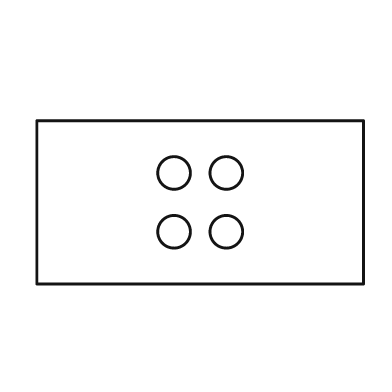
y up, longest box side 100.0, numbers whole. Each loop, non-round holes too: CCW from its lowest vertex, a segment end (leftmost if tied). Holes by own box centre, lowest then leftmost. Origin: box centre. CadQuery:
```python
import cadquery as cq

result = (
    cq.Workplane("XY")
    .moveTo(-50.0, -25.0)
    .lineTo(50.0, -25.0)
    .lineTo(50.0, 25.0)
    .lineTo(-50.0, 25.0)
    .close()
    .moveTo(-8.0, -9.0)
    .circle(5.0)
    .moveTo(8.0, -9.0)
    .circle(5.0)
    .moveTo(-8.0, 9.0)
    .circle(5.0)
    .moveTo(8.0, 9.0)
    .circle(5.0)
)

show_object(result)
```